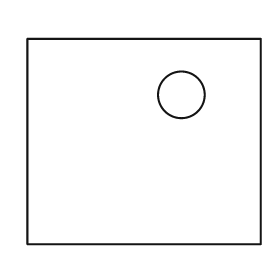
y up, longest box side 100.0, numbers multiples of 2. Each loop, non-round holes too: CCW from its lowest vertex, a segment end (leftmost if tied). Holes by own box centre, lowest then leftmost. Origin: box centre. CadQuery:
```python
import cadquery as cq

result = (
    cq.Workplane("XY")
    .moveTo(-50.0, -44.0)
    .lineTo(50.0, -44.0)
    .lineTo(50.0, 44.0)
    .lineTo(-50.0, 44.0)
    .close()
    .moveTo(16.0, 20.0)
    .circle(10.0)
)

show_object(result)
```